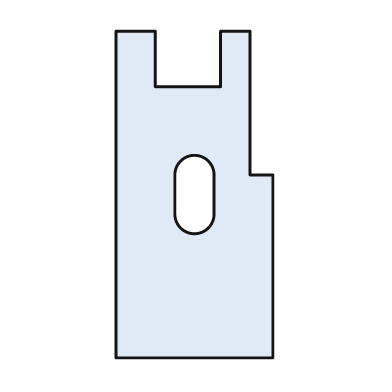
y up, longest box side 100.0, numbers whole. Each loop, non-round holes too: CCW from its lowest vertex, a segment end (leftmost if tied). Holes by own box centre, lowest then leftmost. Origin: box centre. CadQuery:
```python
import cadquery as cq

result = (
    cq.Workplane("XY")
    .moveTo(-24.0, -50.0)
    .lineTo(24.0, -50.0)
    .lineTo(24.0, 6.0)
    .lineTo(17.0, 6.0)
    .lineTo(17.0, 50.0)
    .lineTo(8.0, 50.0)
    .lineTo(8.0, 33.0)
    .lineTo(-12.0, 33.0)
    .lineTo(-12.0, 50.0)
    .lineTo(-24.0, 50.0)
    .close()
    .moveTo(-6.0, -6.0)
    .threePointArc((0.0, -12.0), (6.0, -6.0))
    .lineTo(6.0, 6.0)
    .threePointArc((0.0, 12.0), (-6.0, 6.0))
    .close()
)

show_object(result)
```